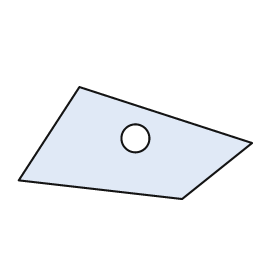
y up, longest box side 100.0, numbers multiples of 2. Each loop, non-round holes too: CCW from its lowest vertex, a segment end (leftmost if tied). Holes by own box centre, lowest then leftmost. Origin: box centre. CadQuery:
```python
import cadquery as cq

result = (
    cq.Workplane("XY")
    .moveTo(20.0, -24.0)
    .lineTo(50.0, 0.0)
    .lineTo(-24.0, 24.0)
    .lineTo(-50.0, -16.0)
    .close()
    .moveTo(0.0, 2.0)
    .circle(6.0)
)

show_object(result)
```